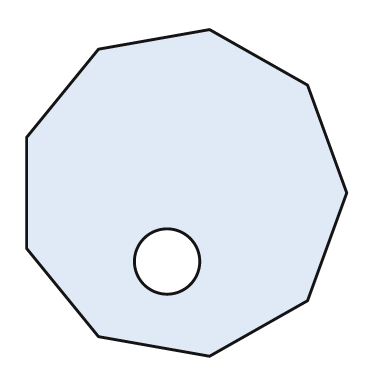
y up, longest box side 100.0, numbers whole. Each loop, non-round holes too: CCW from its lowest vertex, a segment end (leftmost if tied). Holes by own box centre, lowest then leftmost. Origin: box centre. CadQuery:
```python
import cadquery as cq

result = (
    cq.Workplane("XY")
    .moveTo(7.0, -50.0)
    .lineTo(37.0, -33.0)
    .lineTo(49.0, 0.0)
    .lineTo(37.0, 33.0)
    .lineTo(7.0, 50.0)
    .lineTo(-27.0, 44.0)
    .lineTo(-49.0, 17.0)
    .lineTo(-49.0, -17.0)
    .lineTo(-27.0, -44.0)
    .close()
    .moveTo(-6.0, -21.0)
    .circle(10.0)
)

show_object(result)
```